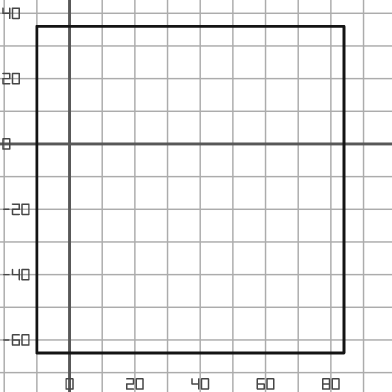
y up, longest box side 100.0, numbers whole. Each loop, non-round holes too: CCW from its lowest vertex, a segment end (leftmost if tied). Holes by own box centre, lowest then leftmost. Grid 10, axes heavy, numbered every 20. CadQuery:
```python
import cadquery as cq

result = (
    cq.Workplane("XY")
    .moveTo(-10.0, -64.0)
    .lineTo(84.0, -64.0)
    .lineTo(84.0, 36.0)
    .lineTo(-10.0, 36.0)
    .close()
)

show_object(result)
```